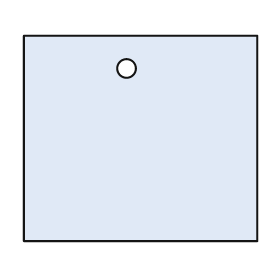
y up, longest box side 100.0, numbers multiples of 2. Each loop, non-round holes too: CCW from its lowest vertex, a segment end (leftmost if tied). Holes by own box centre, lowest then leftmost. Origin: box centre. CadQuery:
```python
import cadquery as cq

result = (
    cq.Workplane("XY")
    .moveTo(-50.0, -44.0)
    .lineTo(50.0, -44.0)
    .lineTo(50.0, 44.0)
    .lineTo(-50.0, 44.0)
    .close()
    .moveTo(-6.0, 30.0)
    .circle(4.0)
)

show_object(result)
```